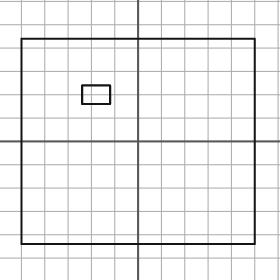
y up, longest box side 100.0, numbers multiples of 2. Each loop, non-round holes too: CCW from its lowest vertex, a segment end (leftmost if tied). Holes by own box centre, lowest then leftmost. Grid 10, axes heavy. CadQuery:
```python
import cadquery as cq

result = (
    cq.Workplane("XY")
    .moveTo(-50.0, -44.0)
    .lineTo(50.0, -44.0)
    .lineTo(50.0, 44.0)
    .lineTo(-50.0, 44.0)
    .close()
    .moveTo(-24.0, 16.0)
    .lineTo(-12.0, 16.0)
    .lineTo(-12.0, 24.0)
    .lineTo(-24.0, 24.0)
    .close()
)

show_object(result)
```